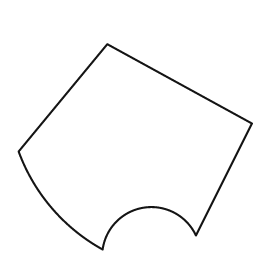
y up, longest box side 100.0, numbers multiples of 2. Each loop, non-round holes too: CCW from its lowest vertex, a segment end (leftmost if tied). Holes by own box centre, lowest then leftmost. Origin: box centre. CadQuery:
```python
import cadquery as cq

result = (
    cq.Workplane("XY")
    .moveTo(-14.0, -44.0)
    .threePointArc((4.0, -26.0), (26.0, -38.0))
    .lineTo(50.0, 10.0)
    .lineTo(-12.0, 44.0)
    .lineTo(-50.0, -2.0)
    .threePointArc((-36.0, -26.0), (-14.0, -44.0))
    .close()
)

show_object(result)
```